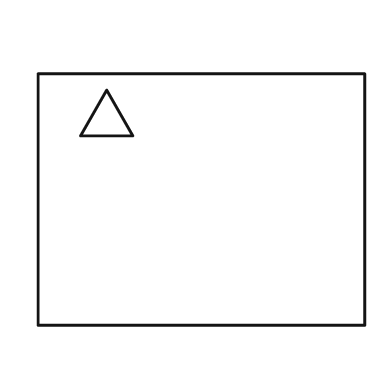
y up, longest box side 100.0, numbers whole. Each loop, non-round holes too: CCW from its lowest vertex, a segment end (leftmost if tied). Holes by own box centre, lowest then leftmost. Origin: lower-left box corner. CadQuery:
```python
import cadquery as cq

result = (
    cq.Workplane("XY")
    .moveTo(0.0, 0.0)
    .lineTo(100.0, 0.0)
    .lineTo(100.0, 77.0)
    .lineTo(0.0, 77.0)
    .close()
    .moveTo(13.0, 58.0)
    .lineTo(29.0, 58.0)
    .lineTo(21.0, 72.0)
    .close()
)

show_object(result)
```